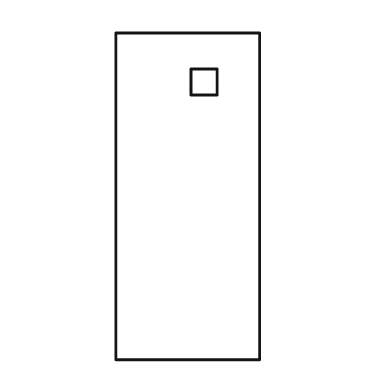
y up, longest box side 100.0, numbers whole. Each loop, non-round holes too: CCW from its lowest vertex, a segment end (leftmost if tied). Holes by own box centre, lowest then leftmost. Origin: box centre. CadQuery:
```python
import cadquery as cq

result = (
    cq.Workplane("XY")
    .moveTo(-22.0, -50.0)
    .lineTo(22.0, -50.0)
    .lineTo(22.0, 50.0)
    .lineTo(-22.0, 50.0)
    .close()
    .moveTo(1.0, 31.0)
    .lineTo(9.0, 31.0)
    .lineTo(9.0, 39.0)
    .lineTo(1.0, 39.0)
    .close()
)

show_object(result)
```